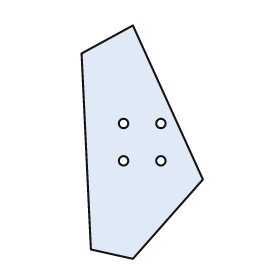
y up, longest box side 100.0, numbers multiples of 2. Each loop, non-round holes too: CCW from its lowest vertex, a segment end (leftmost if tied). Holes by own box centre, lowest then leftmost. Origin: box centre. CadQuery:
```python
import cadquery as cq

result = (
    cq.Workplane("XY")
    .moveTo(-4.0, -50.0)
    .lineTo(26.0, -16.0)
    .lineTo(-4.0, 50.0)
    .lineTo(-26.0, 38.0)
    .lineTo(-22.0, -46.0)
    .close()
    .moveTo(-8.0, -8.0)
    .circle(2.0)
    .moveTo(8.0, -8.0)
    .circle(2.0)
    .moveTo(-8.0, 8.0)
    .circle(2.0)
    .moveTo(8.0, 8.0)
    .circle(2.0)
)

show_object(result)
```